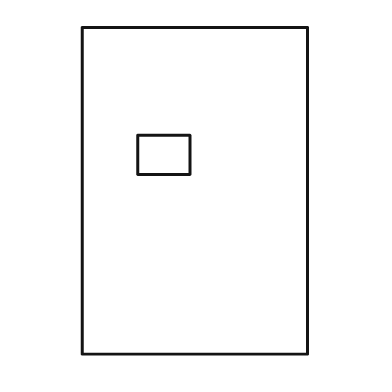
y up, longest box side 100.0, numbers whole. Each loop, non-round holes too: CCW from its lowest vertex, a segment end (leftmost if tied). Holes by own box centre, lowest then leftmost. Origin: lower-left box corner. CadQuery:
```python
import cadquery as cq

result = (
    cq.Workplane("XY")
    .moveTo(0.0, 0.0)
    .lineTo(69.0, 0.0)
    .lineTo(69.0, 100.0)
    .lineTo(0.0, 100.0)
    .close()
    .moveTo(17.0, 55.0)
    .lineTo(33.0, 55.0)
    .lineTo(33.0, 67.0)
    .lineTo(17.0, 67.0)
    .close()
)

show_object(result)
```